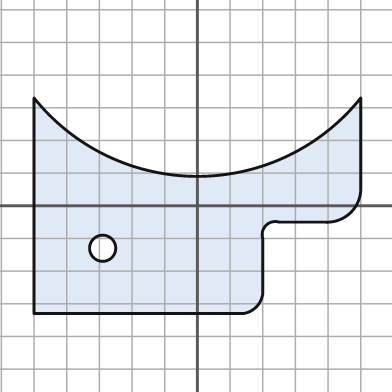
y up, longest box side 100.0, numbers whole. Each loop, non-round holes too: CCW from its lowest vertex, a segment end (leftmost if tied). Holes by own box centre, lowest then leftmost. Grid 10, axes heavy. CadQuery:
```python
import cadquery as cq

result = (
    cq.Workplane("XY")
    .moveTo(-50.0, -33.0)
    .lineTo(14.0, -33.0)
    .threePointArc((18.0, -31.0), (20.0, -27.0))
    .lineTo(20.0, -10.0)
    .threePointArc((21.0, -6.0), (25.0, -5.0))
    .lineTo(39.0, -5.0)
    .threePointArc((47.0, -2.0), (50.0, 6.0))
    .lineTo(50.0, 33.0)
    .threePointArc((0.0, 9.0), (-50.0, 33.0))
    .close()
    .moveTo(-29.0, -13.0)
    .circle(4.0)
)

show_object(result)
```